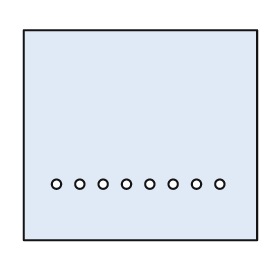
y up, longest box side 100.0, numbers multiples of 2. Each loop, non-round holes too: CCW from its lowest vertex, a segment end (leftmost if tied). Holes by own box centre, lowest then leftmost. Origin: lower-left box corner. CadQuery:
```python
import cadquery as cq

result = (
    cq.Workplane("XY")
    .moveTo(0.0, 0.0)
    .lineTo(100.0, 0.0)
    .lineTo(100.0, 90.0)
    .lineTo(0.0, 90.0)
    .close()
    .moveTo(14.0, 24.0)
    .circle(2.0)
    .moveTo(24.0, 24.0)
    .circle(2.0)
    .moveTo(34.0, 24.0)
    .circle(2.0)
    .moveTo(44.0, 24.0)
    .circle(2.0)
    .moveTo(54.0, 24.0)
    .circle(2.0)
    .moveTo(64.0, 24.0)
    .circle(2.0)
    .moveTo(74.0, 24.0)
    .circle(2.0)
    .moveTo(84.0, 24.0)
    .circle(2.0)
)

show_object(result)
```